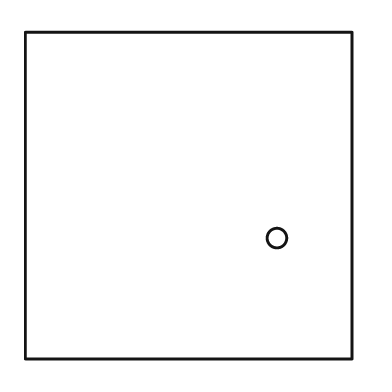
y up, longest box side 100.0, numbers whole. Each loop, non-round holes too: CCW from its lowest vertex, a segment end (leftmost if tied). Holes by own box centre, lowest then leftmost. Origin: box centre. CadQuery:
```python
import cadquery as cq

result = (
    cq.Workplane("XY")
    .moveTo(-50.0, -50.0)
    .lineTo(50.0, -50.0)
    .lineTo(50.0, 50.0)
    .lineTo(-50.0, 50.0)
    .close()
    .moveTo(27.0, -13.0)
    .circle(3.0)
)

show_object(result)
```